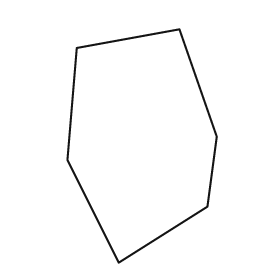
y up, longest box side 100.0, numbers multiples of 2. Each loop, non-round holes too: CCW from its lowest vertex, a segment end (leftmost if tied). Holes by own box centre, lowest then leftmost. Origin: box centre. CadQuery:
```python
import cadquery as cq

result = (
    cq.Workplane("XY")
    .moveTo(-10.0, -50.0)
    .lineTo(28.0, -26.0)
    .lineTo(32.0, 4.0)
    .lineTo(16.0, 50.0)
    .lineTo(-28.0, 42.0)
    .lineTo(-32.0, -6.0)
    .close()
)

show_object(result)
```